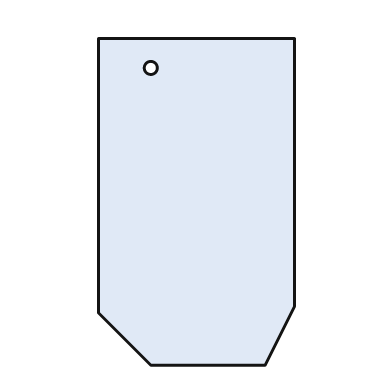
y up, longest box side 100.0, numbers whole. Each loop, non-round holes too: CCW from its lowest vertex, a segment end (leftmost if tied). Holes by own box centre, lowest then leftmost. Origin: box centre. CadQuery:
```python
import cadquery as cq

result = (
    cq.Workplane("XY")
    .moveTo(-14.0, -50.0)
    .lineTo(21.0, -50.0)
    .lineTo(30.0, -32.0)
    .lineTo(30.0, 50.0)
    .lineTo(-30.0, 50.0)
    .lineTo(-30.0, -34.0)
    .close()
    .moveTo(-14.0, 41.0)
    .circle(2.0)
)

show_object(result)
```